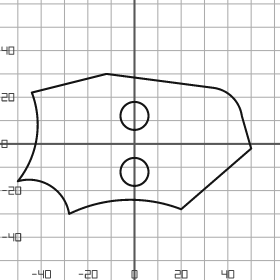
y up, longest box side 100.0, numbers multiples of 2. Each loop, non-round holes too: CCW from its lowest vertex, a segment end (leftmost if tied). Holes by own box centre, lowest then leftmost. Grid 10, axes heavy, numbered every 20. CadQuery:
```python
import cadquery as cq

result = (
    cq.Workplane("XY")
    .moveTo(-28.0, -30.0)
    .threePointArc((-4.0, -24.0), (20.0, -28.0))
    .lineTo(50.0, -2.0)
    .lineTo(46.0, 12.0)
    .threePointArc((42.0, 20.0), (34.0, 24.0))
    .lineTo(-12.0, 30.0)
    .lineTo(-44.0, 22.0)
    .threePointArc((-42.0, 2.0), (-50.0, -16.0))
    .threePointArc((-36.0, -18.0), (-28.0, -30.0))
    .close()
    .moveTo(0.0, -12.0)
    .circle(6.0)
    .moveTo(0.0, 12.0)
    .circle(6.0)
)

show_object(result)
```